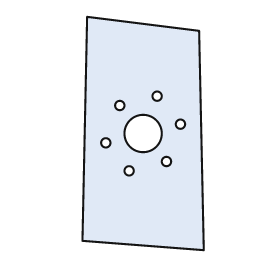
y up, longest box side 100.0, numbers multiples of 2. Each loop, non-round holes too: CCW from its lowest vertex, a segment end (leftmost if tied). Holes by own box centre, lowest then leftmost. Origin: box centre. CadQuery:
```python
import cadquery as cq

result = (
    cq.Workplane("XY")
    .moveTo(26.0, -50.0)
    .lineTo(24.0, 44.0)
    .lineTo(-24.0, 50.0)
    .lineTo(-26.0, -46.0)
    .close()
    .moveTo(-6.0, -16.0)
    .circle(2.0)
    .moveTo(10.0, -12.0)
    .circle(2.0)
    .moveTo(-16.0, -4.0)
    .circle(2.0)
    .moveTo(0.0, 0.0)
    .circle(8.0)
    .moveTo(16.0, 4.0)
    .circle(2.0)
    .moveTo(-10.0, 12.0)
    .circle(2.0)
    .moveTo(6.0, 16.0)
    .circle(2.0)
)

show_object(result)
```